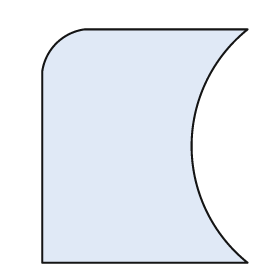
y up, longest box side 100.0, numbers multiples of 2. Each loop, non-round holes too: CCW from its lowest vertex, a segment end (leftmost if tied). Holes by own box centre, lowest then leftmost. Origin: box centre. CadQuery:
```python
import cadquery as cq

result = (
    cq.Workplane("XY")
    .moveTo(-44.0, -50.0)
    .lineTo(44.0, -50.0)
    .threePointArc((20.0, 0.0), (44.0, 50.0))
    .lineTo(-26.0, 50.0)
    .threePointArc((-38.0, 44.0), (-44.0, 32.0))
    .close()
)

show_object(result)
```